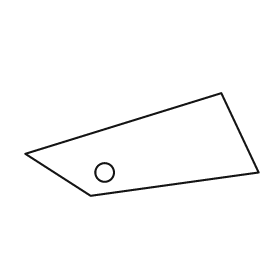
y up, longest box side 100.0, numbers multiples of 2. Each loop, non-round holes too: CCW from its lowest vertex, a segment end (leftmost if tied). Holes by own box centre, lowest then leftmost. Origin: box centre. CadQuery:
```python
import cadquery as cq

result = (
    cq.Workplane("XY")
    .moveTo(-22.0, -22.0)
    .lineTo(50.0, -12.0)
    .lineTo(34.0, 22.0)
    .lineTo(-50.0, -4.0)
    .close()
    .moveTo(-16.0, -12.0)
    .circle(4.0)
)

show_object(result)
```